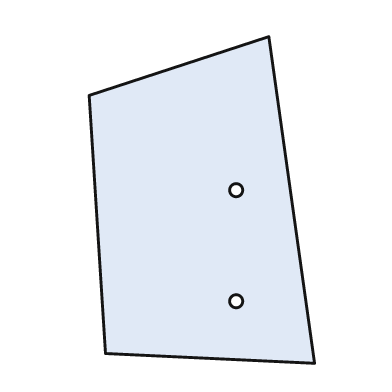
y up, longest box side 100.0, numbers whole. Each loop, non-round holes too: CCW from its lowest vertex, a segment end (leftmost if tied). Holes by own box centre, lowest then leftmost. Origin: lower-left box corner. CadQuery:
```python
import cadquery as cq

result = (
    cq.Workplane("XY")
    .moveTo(69.0, 0.0)
    .lineTo(55.0, 100.0)
    .lineTo(0.0, 82.0)
    .lineTo(5.0, 3.0)
    .close()
    .moveTo(45.0, 19.0)
    .circle(2.0)
    .moveTo(45.0, 53.0)
    .circle(2.0)
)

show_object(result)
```